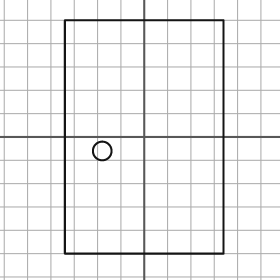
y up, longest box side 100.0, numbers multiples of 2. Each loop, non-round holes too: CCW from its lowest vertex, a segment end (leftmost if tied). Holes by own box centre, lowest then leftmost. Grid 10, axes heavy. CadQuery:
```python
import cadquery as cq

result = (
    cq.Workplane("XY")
    .moveTo(-34.0, -50.0)
    .lineTo(34.0, -50.0)
    .lineTo(34.0, 50.0)
    .lineTo(-34.0, 50.0)
    .close()
    .moveTo(-18.0, -6.0)
    .circle(4.0)
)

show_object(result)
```